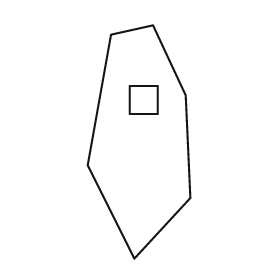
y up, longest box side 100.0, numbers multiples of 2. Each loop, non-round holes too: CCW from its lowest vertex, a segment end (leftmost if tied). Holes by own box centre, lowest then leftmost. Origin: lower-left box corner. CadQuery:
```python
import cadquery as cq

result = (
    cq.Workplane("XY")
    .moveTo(20.0, 0.0)
    .lineTo(44.0, 26.0)
    .lineTo(42.0, 70.0)
    .lineTo(28.0, 100.0)
    .lineTo(10.0, 96.0)
    .lineTo(0.0, 40.0)
    .close()
    .moveTo(18.0, 62.0)
    .lineTo(30.0, 62.0)
    .lineTo(30.0, 74.0)
    .lineTo(18.0, 74.0)
    .close()
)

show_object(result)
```